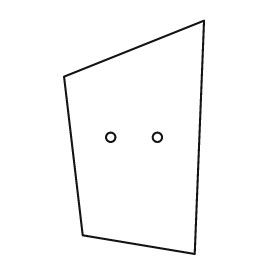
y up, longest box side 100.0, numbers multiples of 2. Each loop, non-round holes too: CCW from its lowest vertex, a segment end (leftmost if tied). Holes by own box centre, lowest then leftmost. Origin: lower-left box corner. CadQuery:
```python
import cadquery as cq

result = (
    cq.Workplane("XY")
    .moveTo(56.0, 0.0)
    .lineTo(60.0, 100.0)
    .lineTo(0.0, 76.0)
    .lineTo(8.0, 8.0)
    .close()
    .moveTo(20.0, 50.0)
    .circle(2.0)
    .moveTo(40.0, 50.0)
    .circle(2.0)
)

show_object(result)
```